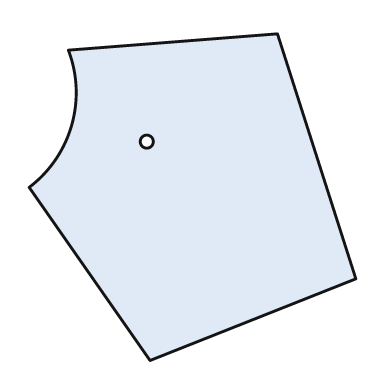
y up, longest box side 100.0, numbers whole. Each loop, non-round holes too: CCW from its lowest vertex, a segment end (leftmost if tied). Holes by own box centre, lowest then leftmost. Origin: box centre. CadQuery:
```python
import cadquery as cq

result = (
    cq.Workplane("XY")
    .moveTo(-13.0, -50.0)
    .lineTo(50.0, -25.0)
    .lineTo(26.0, 50.0)
    .lineTo(-38.0, 45.0)
    .threePointArc((-37.0, 22.0), (-50.0, 3.0))
    .close()
    .moveTo(-14.0, 17.0)
    .circle(2.0)
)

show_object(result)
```